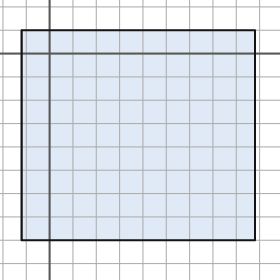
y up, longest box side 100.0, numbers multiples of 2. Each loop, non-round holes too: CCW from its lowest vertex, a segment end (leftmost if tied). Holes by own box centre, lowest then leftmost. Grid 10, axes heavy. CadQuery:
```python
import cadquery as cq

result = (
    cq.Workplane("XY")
    .moveTo(-12.0, -80.0)
    .lineTo(88.0, -80.0)
    .lineTo(88.0, 10.0)
    .lineTo(-12.0, 10.0)
    .close()
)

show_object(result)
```